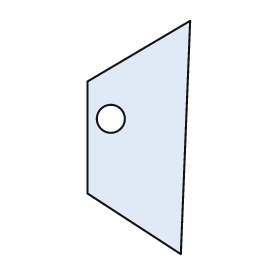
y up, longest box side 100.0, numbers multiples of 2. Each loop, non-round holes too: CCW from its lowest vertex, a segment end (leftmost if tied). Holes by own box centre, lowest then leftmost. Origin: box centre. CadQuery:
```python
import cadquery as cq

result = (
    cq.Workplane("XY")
    .moveTo(18.0, -50.0)
    .lineTo(22.0, 50.0)
    .lineTo(-22.0, 24.0)
    .lineTo(-22.0, -24.0)
    .close()
    .moveTo(-12.0, 8.0)
    .circle(6.0)
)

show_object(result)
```